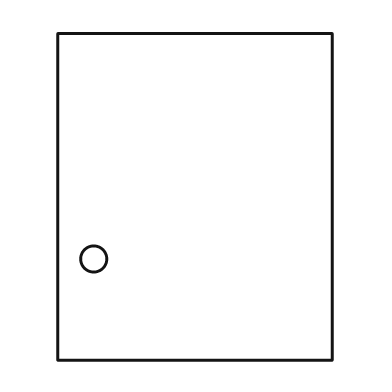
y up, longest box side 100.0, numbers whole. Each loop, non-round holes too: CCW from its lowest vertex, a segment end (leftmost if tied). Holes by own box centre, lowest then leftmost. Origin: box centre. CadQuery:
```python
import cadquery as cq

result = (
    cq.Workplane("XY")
    .moveTo(-42.0, -50.0)
    .lineTo(42.0, -50.0)
    .lineTo(42.0, 50.0)
    .lineTo(-42.0, 50.0)
    .close()
    .moveTo(-31.0, -19.0)
    .circle(4.0)
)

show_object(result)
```